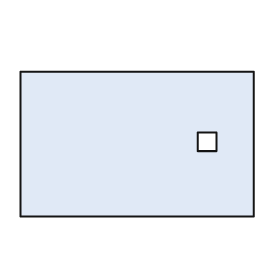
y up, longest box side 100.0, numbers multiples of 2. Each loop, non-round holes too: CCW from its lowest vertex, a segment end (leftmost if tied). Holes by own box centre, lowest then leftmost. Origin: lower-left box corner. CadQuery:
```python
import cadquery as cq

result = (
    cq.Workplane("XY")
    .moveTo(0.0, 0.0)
    .lineTo(100.0, 0.0)
    .lineTo(100.0, 62.0)
    .lineTo(0.0, 62.0)
    .close()
    .moveTo(76.0, 28.0)
    .lineTo(84.0, 28.0)
    .lineTo(84.0, 36.0)
    .lineTo(76.0, 36.0)
    .close()
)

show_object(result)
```